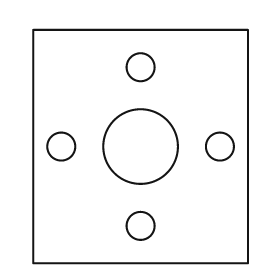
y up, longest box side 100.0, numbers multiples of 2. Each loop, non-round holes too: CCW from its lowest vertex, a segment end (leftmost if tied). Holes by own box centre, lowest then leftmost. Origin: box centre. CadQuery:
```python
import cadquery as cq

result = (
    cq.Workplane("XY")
    .moveTo(-46.0, -50.0)
    .lineTo(46.0, -50.0)
    .lineTo(46.0, 50.0)
    .lineTo(-46.0, 50.0)
    .close()
    .moveTo(0.0, -34.0)
    .circle(6.0)
    .moveTo(-34.0, 0.0)
    .circle(6.0)
    .moveTo(0.0, 0.0)
    .circle(16.0)
    .moveTo(34.0, 0.0)
    .circle(6.0)
    .moveTo(0.0, 34.0)
    .circle(6.0)
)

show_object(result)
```